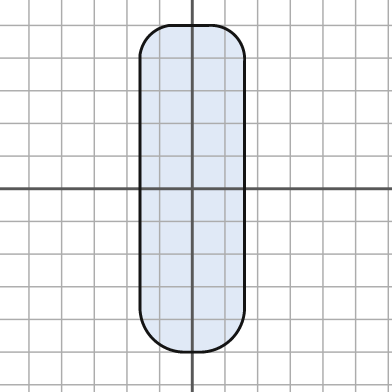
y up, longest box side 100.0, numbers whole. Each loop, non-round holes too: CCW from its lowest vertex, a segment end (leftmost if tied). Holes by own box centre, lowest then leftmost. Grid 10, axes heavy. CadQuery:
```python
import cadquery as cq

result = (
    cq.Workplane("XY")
    .moveTo(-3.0, -50.0)
    .lineTo(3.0, -50.0)
    .threePointArc((12.0, -46.0), (16.0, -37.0))
    .lineTo(16.0, 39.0)
    .threePointArc((13.0, 47.0), (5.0, 50.0))
    .lineTo(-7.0, 50.0)
    .threePointArc((-13.0, 47.0), (-16.0, 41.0))
    .lineTo(-16.0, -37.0)
    .threePointArc((-12.0, -46.0), (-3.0, -50.0))
    .close()
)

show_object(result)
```